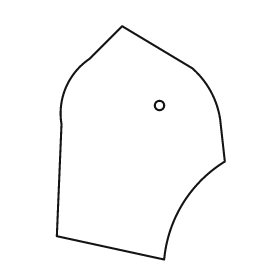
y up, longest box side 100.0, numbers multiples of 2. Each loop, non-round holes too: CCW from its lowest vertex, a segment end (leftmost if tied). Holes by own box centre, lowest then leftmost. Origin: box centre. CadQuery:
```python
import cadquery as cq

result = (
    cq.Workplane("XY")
    .moveTo(10.0, -50.0)
    .threePointArc((18.0, -26.0), (36.0, -8.0))
    .lineTo(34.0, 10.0)
    .threePointArc((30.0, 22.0), (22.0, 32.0))
    .lineTo(-8.0, 50.0)
    .lineTo(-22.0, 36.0)
    .threePointArc((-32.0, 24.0), (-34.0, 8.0))
    .lineTo(-36.0, -40.0)
    .close()
    .moveTo(8.0, 16.0)
    .circle(2.0)
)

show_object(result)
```